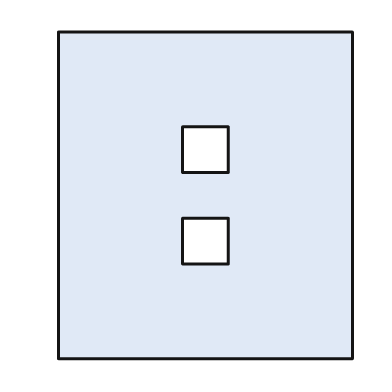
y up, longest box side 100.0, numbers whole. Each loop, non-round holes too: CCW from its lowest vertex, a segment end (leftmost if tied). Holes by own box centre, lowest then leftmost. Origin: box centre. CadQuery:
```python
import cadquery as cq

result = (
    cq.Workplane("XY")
    .moveTo(-45.0, -50.0)
    .lineTo(45.0, -50.0)
    .lineTo(45.0, 50.0)
    .lineTo(-45.0, 50.0)
    .close()
    .moveTo(-7.0, -21.0)
    .lineTo(7.0, -21.0)
    .lineTo(7.0, -7.0)
    .lineTo(-7.0, -7.0)
    .close()
    .moveTo(-7.0, 7.0)
    .lineTo(7.0, 7.0)
    .lineTo(7.0, 21.0)
    .lineTo(-7.0, 21.0)
    .close()
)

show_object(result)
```